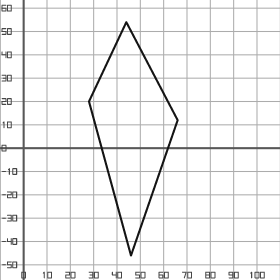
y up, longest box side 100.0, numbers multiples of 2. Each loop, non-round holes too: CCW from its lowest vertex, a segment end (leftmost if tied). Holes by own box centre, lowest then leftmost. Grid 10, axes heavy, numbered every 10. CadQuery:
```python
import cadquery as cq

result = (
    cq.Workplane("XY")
    .moveTo(46.0, -46.0)
    .lineTo(66.0, 12.0)
    .lineTo(44.0, 54.0)
    .lineTo(28.0, 20.0)
    .close()
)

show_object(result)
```